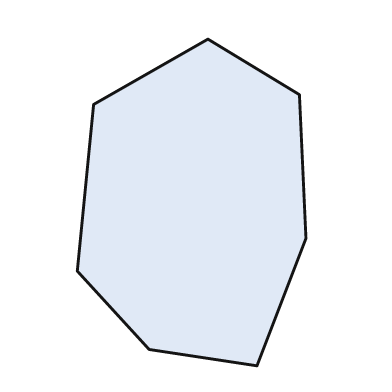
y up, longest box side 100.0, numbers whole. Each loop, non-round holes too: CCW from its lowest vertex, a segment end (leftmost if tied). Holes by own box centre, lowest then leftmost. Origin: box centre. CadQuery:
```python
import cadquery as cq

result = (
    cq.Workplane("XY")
    .moveTo(20.0, -50.0)
    .lineTo(35.0, -11.0)
    .lineTo(33.0, 33.0)
    .lineTo(5.0, 50.0)
    .lineTo(-30.0, 30.0)
    .lineTo(-35.0, -21.0)
    .lineTo(-13.0, -45.0)
    .close()
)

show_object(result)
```